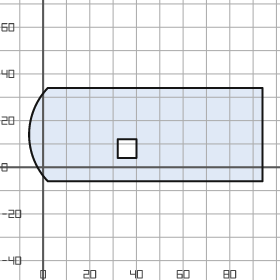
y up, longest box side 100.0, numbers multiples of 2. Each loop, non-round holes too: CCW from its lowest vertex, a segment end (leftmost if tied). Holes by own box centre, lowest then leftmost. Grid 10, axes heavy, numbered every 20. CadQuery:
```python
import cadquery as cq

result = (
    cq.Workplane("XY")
    .moveTo(2.0, -6.0)
    .lineTo(94.0, -6.0)
    .lineTo(94.0, 34.0)
    .lineTo(2.0, 34.0)
    .threePointArc((-6.0, 14.0), (2.0, -6.0))
    .close()
    .moveTo(32.0, 4.0)
    .lineTo(40.0, 4.0)
    .lineTo(40.0, 12.0)
    .lineTo(32.0, 12.0)
    .close()
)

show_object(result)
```